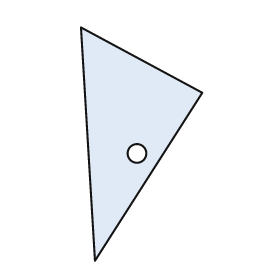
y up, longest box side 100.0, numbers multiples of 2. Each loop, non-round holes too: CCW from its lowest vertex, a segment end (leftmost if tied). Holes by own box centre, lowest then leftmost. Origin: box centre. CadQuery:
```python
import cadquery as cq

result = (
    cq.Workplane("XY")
    .moveTo(-20.0, -50.0)
    .lineTo(26.0, 22.0)
    .lineTo(-26.0, 50.0)
    .close()
    .moveTo(-2.0, -4.0)
    .circle(4.0)
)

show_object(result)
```